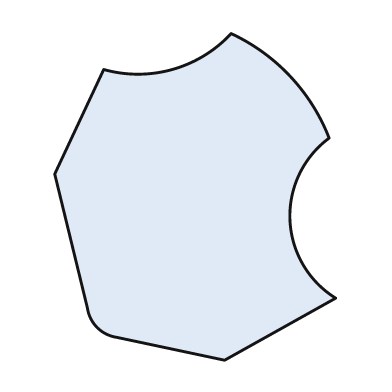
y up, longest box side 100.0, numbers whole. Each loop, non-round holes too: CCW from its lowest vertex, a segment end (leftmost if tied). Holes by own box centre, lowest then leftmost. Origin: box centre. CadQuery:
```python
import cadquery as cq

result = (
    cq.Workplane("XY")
    .moveTo(9.0, -50.0)
    .lineTo(43.0, -31.0)
    .threePointArc((29.0, -7.0), (41.0, 18.0))
    .threePointArc((29.0, 37.0), (11.0, 50.0))
    .threePointArc((-7.0, 39.0), (-28.0, 39.0))
    .lineTo(-43.0, 7.0)
    .lineTo(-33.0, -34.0)
    .threePointArc((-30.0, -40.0), (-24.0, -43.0))
    .close()
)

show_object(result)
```